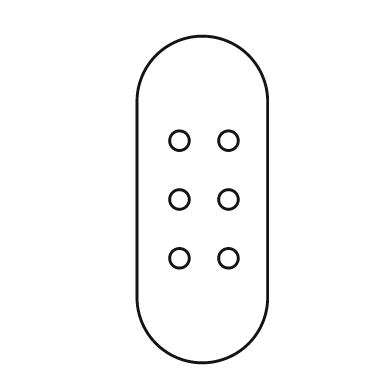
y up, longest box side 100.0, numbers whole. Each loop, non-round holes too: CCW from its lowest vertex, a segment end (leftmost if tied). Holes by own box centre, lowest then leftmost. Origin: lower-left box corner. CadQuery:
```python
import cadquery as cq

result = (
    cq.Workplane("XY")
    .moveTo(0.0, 20.0)
    .threePointArc((20.0, 0.0), (40.0, 20.0))
    .lineTo(40.0, 80.0)
    .threePointArc((20.0, 100.0), (0.0, 80.0))
    .close()
    .moveTo(13.0, 32.0)
    .circle(3.0)
    .moveTo(28.0, 32.0)
    .circle(3.0)
    .moveTo(13.0, 50.0)
    .circle(3.0)
    .moveTo(28.0, 50.0)
    .circle(3.0)
    .moveTo(13.0, 68.0)
    .circle(3.0)
    .moveTo(28.0, 68.0)
    .circle(3.0)
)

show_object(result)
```